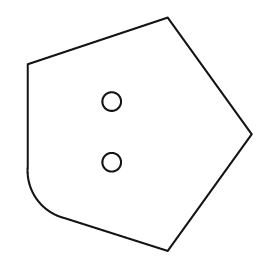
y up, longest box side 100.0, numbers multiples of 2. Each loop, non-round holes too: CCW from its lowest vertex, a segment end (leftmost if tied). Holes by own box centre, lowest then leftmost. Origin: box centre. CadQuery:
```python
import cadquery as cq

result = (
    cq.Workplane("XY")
    .moveTo(12.0, -50.0)
    .lineTo(48.0, 0.0)
    .lineTo(12.0, 50.0)
    .lineTo(-48.0, 30.0)
    .lineTo(-48.0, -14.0)
    .threePointArc((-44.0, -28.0), (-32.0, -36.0))
    .close()
    .moveTo(-12.0, -12.0)
    .circle(4.0)
    .moveTo(-12.0, 14.0)
    .circle(4.0)
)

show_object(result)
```